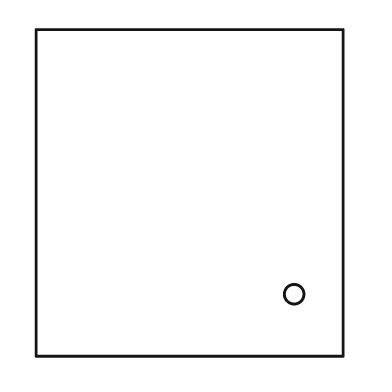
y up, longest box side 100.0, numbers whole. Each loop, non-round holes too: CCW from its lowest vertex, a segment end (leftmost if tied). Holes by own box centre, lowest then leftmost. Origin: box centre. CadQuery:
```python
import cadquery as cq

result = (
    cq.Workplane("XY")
    .moveTo(-47.0, -50.0)
    .lineTo(47.0, -50.0)
    .lineTo(47.0, 50.0)
    .lineTo(-47.0, 50.0)
    .close()
    .moveTo(32.0, -31.0)
    .circle(3.0)
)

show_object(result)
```